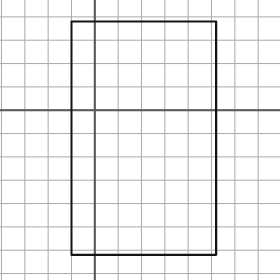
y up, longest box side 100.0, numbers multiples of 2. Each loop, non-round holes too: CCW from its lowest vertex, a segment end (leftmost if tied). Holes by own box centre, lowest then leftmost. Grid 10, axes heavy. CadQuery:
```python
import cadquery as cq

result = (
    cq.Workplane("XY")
    .moveTo(-10.0, -62.0)
    .lineTo(52.0, -62.0)
    .lineTo(52.0, 38.0)
    .lineTo(-10.0, 38.0)
    .close()
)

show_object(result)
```